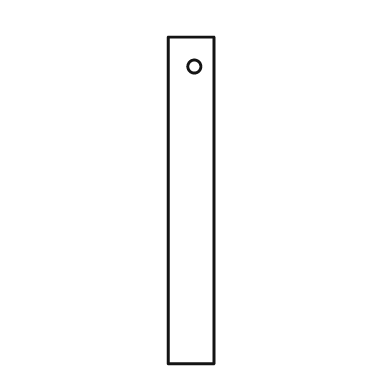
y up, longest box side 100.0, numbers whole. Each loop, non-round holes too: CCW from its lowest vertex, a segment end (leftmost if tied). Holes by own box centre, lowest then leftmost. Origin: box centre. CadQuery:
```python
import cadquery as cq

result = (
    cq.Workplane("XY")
    .moveTo(-7.0, -50.0)
    .lineTo(7.0, -50.0)
    .lineTo(7.0, 50.0)
    .lineTo(-7.0, 50.0)
    .close()
    .moveTo(1.0, 41.0)
    .circle(2.0)
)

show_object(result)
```